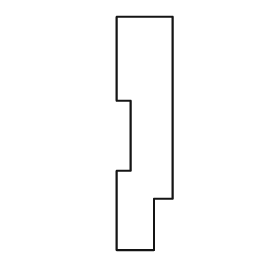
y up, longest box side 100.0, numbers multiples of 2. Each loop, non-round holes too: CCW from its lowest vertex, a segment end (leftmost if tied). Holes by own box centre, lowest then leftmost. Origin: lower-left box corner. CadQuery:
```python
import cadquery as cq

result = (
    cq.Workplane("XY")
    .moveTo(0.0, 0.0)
    .lineTo(16.0, 0.0)
    .lineTo(16.0, 22.0)
    .lineTo(24.0, 22.0)
    .lineTo(24.0, 100.0)
    .lineTo(0.0, 100.0)
    .lineTo(0.0, 64.0)
    .lineTo(6.0, 64.0)
    .lineTo(6.0, 34.0)
    .lineTo(0.0, 34.0)
    .close()
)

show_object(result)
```